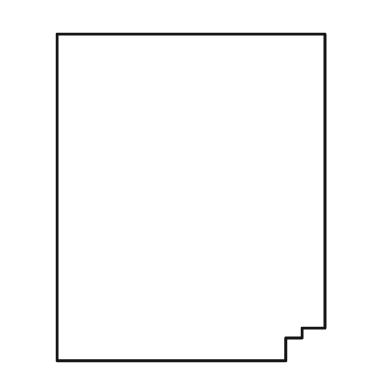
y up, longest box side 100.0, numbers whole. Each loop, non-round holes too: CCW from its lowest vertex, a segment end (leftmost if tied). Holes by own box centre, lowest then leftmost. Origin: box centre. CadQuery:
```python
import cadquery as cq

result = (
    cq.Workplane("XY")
    .moveTo(-41.0, -50.0)
    .lineTo(29.0, -50.0)
    .lineTo(29.0, -43.0)
    .lineTo(34.0, -43.0)
    .lineTo(34.0, -40.0)
    .lineTo(41.0, -40.0)
    .lineTo(41.0, 50.0)
    .lineTo(-41.0, 50.0)
    .close()
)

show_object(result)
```